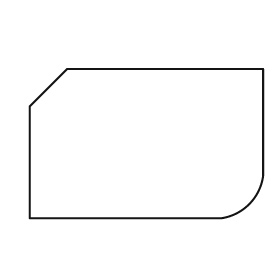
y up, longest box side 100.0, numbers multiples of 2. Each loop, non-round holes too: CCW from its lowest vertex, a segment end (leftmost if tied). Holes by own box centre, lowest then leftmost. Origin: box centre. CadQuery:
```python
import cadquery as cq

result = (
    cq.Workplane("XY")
    .moveTo(-50.0, -32.0)
    .lineTo(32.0, -32.0)
    .threePointArc((44.0, -26.0), (50.0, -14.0))
    .lineTo(50.0, 32.0)
    .lineTo(-34.0, 32.0)
    .lineTo(-50.0, 16.0)
    .close()
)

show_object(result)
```